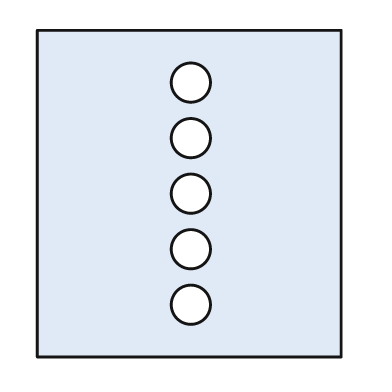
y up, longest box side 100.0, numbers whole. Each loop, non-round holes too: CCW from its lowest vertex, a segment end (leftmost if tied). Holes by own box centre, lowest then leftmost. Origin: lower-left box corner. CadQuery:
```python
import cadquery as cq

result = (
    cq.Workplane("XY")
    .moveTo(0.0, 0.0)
    .lineTo(93.0, 0.0)
    .lineTo(93.0, 100.0)
    .lineTo(0.0, 100.0)
    .close()
    .moveTo(47.0, 16.0)
    .circle(6.0)
    .moveTo(47.0, 33.0)
    .circle(6.0)
    .moveTo(47.0, 50.0)
    .circle(6.0)
    .moveTo(47.0, 67.0)
    .circle(6.0)
    .moveTo(47.0, 84.0)
    .circle(6.0)
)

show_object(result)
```